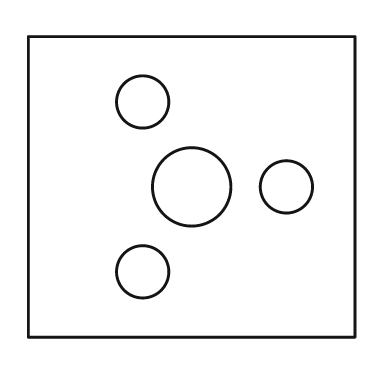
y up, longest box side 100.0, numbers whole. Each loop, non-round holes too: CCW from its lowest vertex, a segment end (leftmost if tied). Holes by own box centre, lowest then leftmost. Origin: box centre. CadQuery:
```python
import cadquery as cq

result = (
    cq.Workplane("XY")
    .moveTo(-50.0, -46.0)
    .lineTo(50.0, -46.0)
    .lineTo(50.0, 46.0)
    .lineTo(-50.0, 46.0)
    .close()
    .moveTo(-15.0, -26.0)
    .circle(8.0)
    .moveTo(0.0, 0.0)
    .circle(12.0)
    .moveTo(29.0, 0.0)
    .circle(8.0)
    .moveTo(-15.0, 26.0)
    .circle(8.0)
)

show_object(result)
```